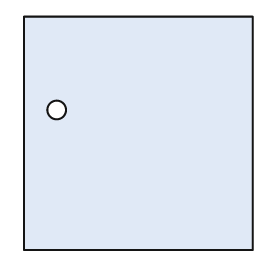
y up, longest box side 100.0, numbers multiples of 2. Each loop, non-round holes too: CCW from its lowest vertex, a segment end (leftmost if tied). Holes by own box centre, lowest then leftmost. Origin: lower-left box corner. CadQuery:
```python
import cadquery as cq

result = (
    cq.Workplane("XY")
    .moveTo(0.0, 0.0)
    .lineTo(98.0, 0.0)
    .lineTo(98.0, 100.0)
    .lineTo(0.0, 100.0)
    .close()
    .moveTo(14.0, 60.0)
    .circle(4.0)
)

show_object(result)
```